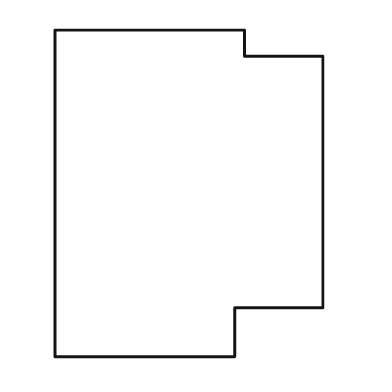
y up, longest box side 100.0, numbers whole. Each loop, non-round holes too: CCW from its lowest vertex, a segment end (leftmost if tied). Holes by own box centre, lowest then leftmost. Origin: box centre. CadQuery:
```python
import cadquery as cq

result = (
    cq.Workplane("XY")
    .moveTo(-41.0, -50.0)
    .lineTo(14.0, -50.0)
    .lineTo(14.0, -35.0)
    .lineTo(41.0, -35.0)
    .lineTo(41.0, 42.0)
    .lineTo(17.0, 42.0)
    .lineTo(17.0, 50.0)
    .lineTo(-41.0, 50.0)
    .close()
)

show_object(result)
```